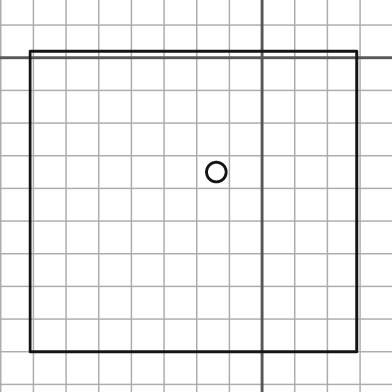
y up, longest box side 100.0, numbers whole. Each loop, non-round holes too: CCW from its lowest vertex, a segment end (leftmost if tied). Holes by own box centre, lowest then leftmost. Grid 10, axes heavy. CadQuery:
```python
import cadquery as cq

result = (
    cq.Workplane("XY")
    .moveTo(-71.0, -90.0)
    .lineTo(29.0, -90.0)
    .lineTo(29.0, 2.0)
    .lineTo(-71.0, 2.0)
    .close()
    .moveTo(-14.0, -35.0)
    .circle(3.0)
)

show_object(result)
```